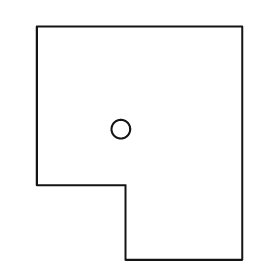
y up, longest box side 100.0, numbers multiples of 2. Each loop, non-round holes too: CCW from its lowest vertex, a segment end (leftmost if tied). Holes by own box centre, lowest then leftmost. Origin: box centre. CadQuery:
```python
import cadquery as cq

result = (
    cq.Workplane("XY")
    .moveTo(-6.0, -50.0)
    .lineTo(44.0, -50.0)
    .lineTo(44.0, 50.0)
    .lineTo(-44.0, 50.0)
    .lineTo(-44.0, -18.0)
    .lineTo(-6.0, -18.0)
    .close()
    .moveTo(-8.0, 6.0)
    .circle(4.0)
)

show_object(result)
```